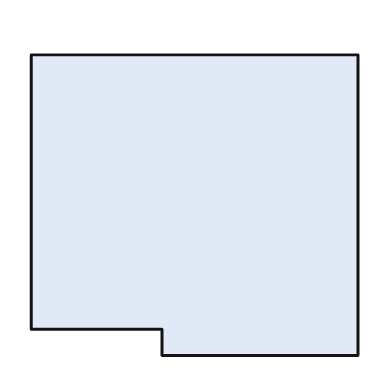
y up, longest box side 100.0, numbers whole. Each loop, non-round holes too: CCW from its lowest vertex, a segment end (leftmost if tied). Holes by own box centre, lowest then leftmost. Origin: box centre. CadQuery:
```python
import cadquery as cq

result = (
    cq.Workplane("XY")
    .moveTo(-10.0, -46.0)
    .lineTo(50.0, -46.0)
    .lineTo(50.0, 46.0)
    .lineTo(-50.0, 46.0)
    .lineTo(-50.0, -38.0)
    .lineTo(-10.0, -38.0)
    .close()
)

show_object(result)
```